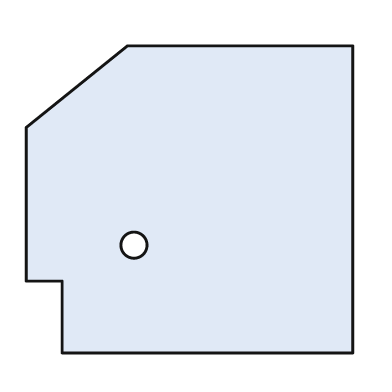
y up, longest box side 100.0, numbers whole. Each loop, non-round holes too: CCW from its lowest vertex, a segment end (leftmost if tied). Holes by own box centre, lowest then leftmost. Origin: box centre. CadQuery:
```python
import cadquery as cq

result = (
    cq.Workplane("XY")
    .moveTo(-39.0, -47.0)
    .lineTo(50.0, -47.0)
    .lineTo(50.0, 47.0)
    .lineTo(-19.0, 47.0)
    .lineTo(-50.0, 22.0)
    .lineTo(-50.0, -25.0)
    .lineTo(-39.0, -25.0)
    .close()
    .moveTo(-17.0, -14.0)
    .circle(4.0)
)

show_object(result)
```